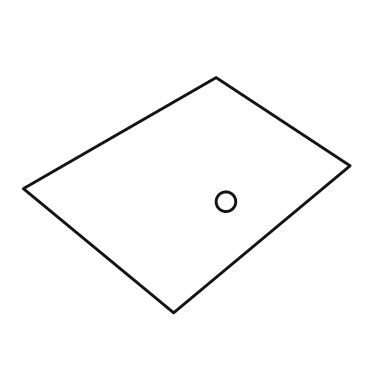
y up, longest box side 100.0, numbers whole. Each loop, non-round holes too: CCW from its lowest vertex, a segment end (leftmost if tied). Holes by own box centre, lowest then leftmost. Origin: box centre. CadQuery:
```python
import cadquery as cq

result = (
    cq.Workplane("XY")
    .moveTo(-4.0, -36.0)
    .lineTo(50.0, 9.0)
    .lineTo(9.0, 36.0)
    .lineTo(-50.0, 2.0)
    .close()
    .moveTo(12.0, -2.0)
    .circle(3.0)
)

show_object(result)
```